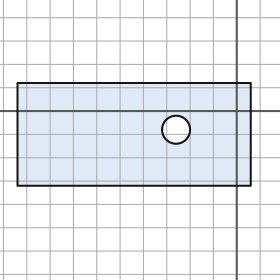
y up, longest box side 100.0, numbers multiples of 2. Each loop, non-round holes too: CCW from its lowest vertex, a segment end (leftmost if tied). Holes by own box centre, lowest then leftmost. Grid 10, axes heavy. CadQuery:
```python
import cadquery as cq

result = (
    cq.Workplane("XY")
    .moveTo(-94.0, -32.0)
    .lineTo(6.0, -32.0)
    .lineTo(6.0, 12.0)
    .lineTo(-94.0, 12.0)
    .close()
    .moveTo(-26.0, -8.0)
    .circle(6.0)
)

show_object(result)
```